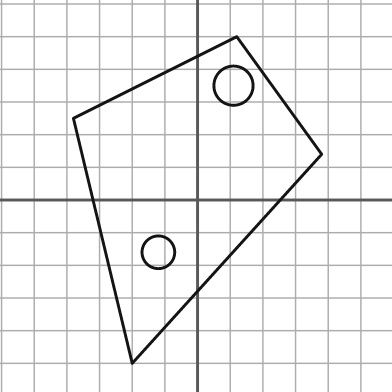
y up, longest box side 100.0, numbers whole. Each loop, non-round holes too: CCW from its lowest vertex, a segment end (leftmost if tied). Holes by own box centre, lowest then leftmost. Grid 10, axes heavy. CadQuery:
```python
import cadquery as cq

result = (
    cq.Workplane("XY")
    .moveTo(-20.0, -50.0)
    .lineTo(38.0, 14.0)
    .lineTo(12.0, 50.0)
    .lineTo(-38.0, 25.0)
    .close()
    .moveTo(-12.0, -16.0)
    .circle(5.0)
    .moveTo(11.0, 35.0)
    .circle(6.0)
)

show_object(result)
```